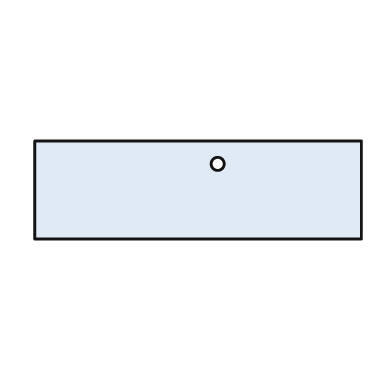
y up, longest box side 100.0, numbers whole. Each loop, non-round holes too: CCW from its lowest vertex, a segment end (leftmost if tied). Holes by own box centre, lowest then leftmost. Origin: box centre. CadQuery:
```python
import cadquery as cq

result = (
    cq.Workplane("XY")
    .moveTo(-50.0, -15.0)
    .lineTo(50.0, -15.0)
    .lineTo(50.0, 15.0)
    .lineTo(-50.0, 15.0)
    .close()
    .moveTo(6.0, 8.0)
    .circle(2.0)
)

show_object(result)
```